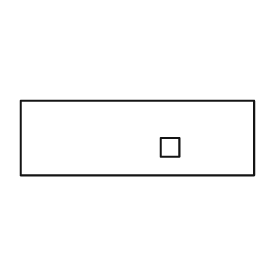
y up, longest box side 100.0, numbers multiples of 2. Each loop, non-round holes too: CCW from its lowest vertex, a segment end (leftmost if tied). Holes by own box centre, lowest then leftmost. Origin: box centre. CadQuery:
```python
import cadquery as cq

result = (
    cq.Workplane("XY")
    .moveTo(-50.0, -16.0)
    .lineTo(50.0, -16.0)
    .lineTo(50.0, 16.0)
    .lineTo(-50.0, 16.0)
    .close()
    .moveTo(10.0, -8.0)
    .lineTo(18.0, -8.0)
    .lineTo(18.0, 0.0)
    .lineTo(10.0, 0.0)
    .close()
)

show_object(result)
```